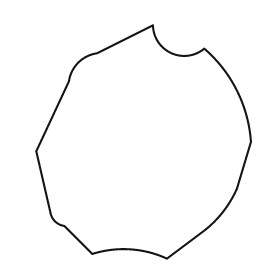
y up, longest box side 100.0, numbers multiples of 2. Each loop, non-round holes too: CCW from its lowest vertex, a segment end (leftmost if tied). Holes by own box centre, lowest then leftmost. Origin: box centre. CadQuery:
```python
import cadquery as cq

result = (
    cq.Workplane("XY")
    .moveTo(10.0, -50.0)
    .lineTo(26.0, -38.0)
    .threePointArc((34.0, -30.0), (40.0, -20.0))
    .lineTo(46.0, 0.0)
    .threePointArc((40.0, 22.0), (26.0, 40.0))
    .threePointArc((12.0, 38.0), (4.0, 50.0))
    .lineTo(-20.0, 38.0)
    .threePointArc((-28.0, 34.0), (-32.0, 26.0))
    .lineTo(-46.0, -4.0)
    .lineTo(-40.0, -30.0)
    .threePointArc((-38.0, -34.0), (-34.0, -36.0))
    .lineTo(-22.0, -48.0)
    .threePointArc((-6.0, -46.0), (10.0, -50.0))
    .close()
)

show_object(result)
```